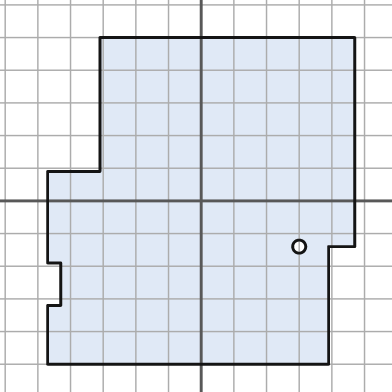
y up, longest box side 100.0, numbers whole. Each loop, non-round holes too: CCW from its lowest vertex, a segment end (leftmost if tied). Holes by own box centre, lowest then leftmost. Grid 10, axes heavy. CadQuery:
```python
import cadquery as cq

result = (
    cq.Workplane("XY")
    .moveTo(-47.0, -50.0)
    .lineTo(39.0, -50.0)
    .lineTo(39.0, -14.0)
    .lineTo(47.0, -14.0)
    .lineTo(47.0, 50.0)
    .lineTo(-31.0, 50.0)
    .lineTo(-31.0, 9.0)
    .lineTo(-47.0, 9.0)
    .lineTo(-47.0, -19.0)
    .lineTo(-43.0, -19.0)
    .lineTo(-43.0, -32.0)
    .lineTo(-47.0, -32.0)
    .close()
    .moveTo(30.0, -14.0)
    .circle(2.0)
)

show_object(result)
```